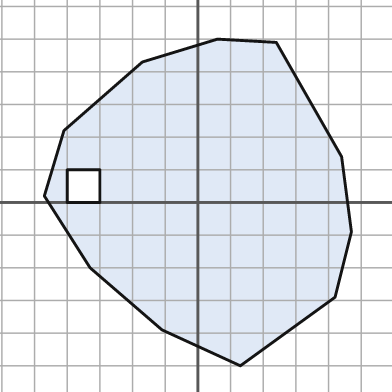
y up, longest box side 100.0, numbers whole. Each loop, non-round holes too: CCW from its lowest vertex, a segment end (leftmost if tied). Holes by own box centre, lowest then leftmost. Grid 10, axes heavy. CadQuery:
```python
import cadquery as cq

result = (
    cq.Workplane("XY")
    .moveTo(13.0, -50.0)
    .lineTo(42.0, -29.0)
    .lineTo(47.0, -9.0)
    .lineTo(44.0, 14.0)
    .lineTo(24.0, 49.0)
    .lineTo(6.0, 50.0)
    .lineTo(-17.0, 43.0)
    .lineTo(-41.0, 22.0)
    .lineTo(-47.0, 2.0)
    .lineTo(-33.0, -20.0)
    .lineTo(-11.0, -39.0)
    .close()
    .moveTo(-40.0, 0.0)
    .lineTo(-30.0, 0.0)
    .lineTo(-30.0, 10.0)
    .lineTo(-40.0, 10.0)
    .close()
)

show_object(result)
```